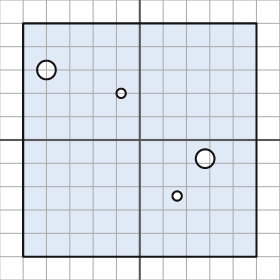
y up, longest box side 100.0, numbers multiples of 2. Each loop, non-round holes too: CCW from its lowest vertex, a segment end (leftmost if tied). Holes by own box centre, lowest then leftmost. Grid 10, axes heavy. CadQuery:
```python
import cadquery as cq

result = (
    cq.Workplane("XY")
    .moveTo(-50.0, -50.0)
    .lineTo(50.0, -50.0)
    .lineTo(50.0, 50.0)
    .lineTo(-50.0, 50.0)
    .close()
    .moveTo(16.0, -24.0)
    .circle(2.0)
    .moveTo(28.0, -8.0)
    .circle(4.0)
    .moveTo(-8.0, 20.0)
    .circle(2.0)
    .moveTo(-40.0, 30.0)
    .circle(4.0)
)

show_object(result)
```